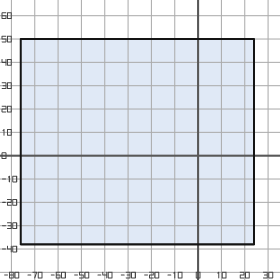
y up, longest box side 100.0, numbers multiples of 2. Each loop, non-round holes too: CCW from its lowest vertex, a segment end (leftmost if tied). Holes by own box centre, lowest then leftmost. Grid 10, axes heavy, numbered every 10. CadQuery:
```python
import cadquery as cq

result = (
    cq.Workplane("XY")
    .moveTo(-76.0, -38.0)
    .lineTo(24.0, -38.0)
    .lineTo(24.0, 50.0)
    .lineTo(-76.0, 50.0)
    .close()
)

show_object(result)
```